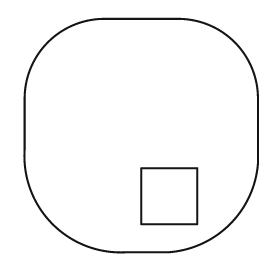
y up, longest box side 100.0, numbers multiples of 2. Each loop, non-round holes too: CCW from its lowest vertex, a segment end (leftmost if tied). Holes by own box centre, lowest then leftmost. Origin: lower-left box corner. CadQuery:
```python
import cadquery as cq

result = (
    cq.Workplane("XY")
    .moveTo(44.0, 0.0)
    .lineTo(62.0, 0.0)
    .threePointArc((88.0, 12.0), (100.0, 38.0))
    .lineTo(100.0, 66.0)
    .threePointArc((90.0, 90.0), (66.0, 100.0))
    .lineTo(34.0, 100.0)
    .threePointArc((10.0, 90.0), (0.0, 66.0))
    .lineTo(0.0, 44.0)
    .threePointArc((12.0, 12.0), (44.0, 0.0))
    .close()
    .moveTo(50.0, 12.0)
    .lineTo(74.0, 12.0)
    .lineTo(74.0, 36.0)
    .lineTo(50.0, 36.0)
    .close()
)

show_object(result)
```